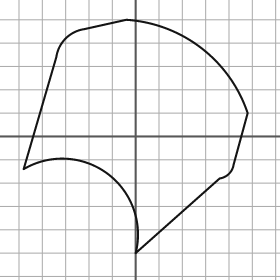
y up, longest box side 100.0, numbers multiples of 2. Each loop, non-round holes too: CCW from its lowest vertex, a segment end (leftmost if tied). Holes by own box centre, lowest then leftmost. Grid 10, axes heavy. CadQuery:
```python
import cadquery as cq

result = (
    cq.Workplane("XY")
    .moveTo(0.0, -50.0)
    .lineTo(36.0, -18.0)
    .threePointArc((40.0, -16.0), (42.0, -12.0))
    .lineTo(48.0, 10.0)
    .threePointArc((28.0, 38.0), (-4.0, 50.0))
    .lineTo(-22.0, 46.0)
    .threePointArc((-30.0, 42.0), (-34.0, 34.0))
    .lineTo(-48.0, -14.0)
    .threePointArc((-12.0, -16.0), (0.0, -50.0))
    .close()
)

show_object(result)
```